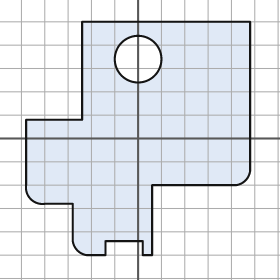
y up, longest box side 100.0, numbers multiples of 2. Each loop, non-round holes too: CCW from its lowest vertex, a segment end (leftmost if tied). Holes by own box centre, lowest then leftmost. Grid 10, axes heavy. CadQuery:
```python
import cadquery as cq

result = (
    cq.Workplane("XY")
    .moveTo(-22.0, -50.0)
    .lineTo(-14.0, -50.0)
    .lineTo(-14.0, -44.0)
    .lineTo(2.0, -44.0)
    .lineTo(2.0, -50.0)
    .lineTo(6.0, -50.0)
    .lineTo(6.0, -20.0)
    .lineTo(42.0, -20.0)
    .threePointArc((46.0, -18.0), (48.0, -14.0))
    .lineTo(48.0, 50.0)
    .lineTo(-24.0, 50.0)
    .lineTo(-24.0, 8.0)
    .lineTo(-48.0, 8.0)
    .lineTo(-48.0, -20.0)
    .threePointArc((-46.0, -26.0), (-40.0, -28.0))
    .lineTo(-28.0, -28.0)
    .lineTo(-28.0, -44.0)
    .threePointArc((-26.0, -48.0), (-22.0, -50.0))
    .close()
    .moveTo(0.0, 34.0)
    .circle(10.0)
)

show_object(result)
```